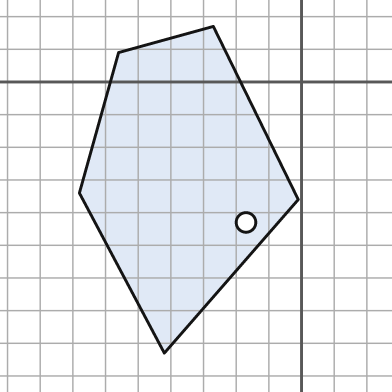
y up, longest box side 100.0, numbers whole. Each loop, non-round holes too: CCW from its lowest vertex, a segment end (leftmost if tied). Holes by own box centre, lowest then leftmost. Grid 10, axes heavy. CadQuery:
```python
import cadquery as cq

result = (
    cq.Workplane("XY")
    .moveTo(-42.0, -83.0)
    .lineTo(-1.0, -36.0)
    .lineTo(-27.0, 17.0)
    .lineTo(-56.0, 9.0)
    .lineTo(-68.0, -34.0)
    .close()
    .moveTo(-17.0, -43.0)
    .circle(3.0)
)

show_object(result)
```